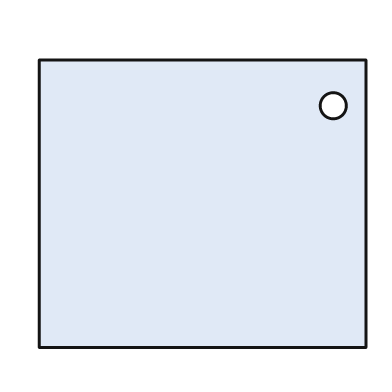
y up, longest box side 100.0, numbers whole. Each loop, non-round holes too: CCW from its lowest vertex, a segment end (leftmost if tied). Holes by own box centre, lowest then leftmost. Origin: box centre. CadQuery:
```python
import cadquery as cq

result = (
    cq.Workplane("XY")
    .moveTo(-50.0, -44.0)
    .lineTo(50.0, -44.0)
    .lineTo(50.0, 44.0)
    .lineTo(-50.0, 44.0)
    .close()
    .moveTo(40.0, 30.0)
    .circle(4.0)
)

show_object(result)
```